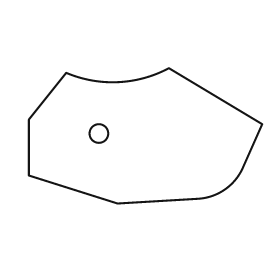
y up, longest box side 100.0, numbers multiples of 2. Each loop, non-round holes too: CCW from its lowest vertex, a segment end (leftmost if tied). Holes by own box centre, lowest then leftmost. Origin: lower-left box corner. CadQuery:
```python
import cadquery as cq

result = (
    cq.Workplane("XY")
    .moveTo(38.0, 0.0)
    .lineTo(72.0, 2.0)
    .threePointArc((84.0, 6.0), (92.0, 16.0))
    .lineTo(100.0, 34.0)
    .lineTo(60.0, 58.0)
    .threePointArc((38.0, 52.0), (16.0, 56.0))
    .lineTo(0.0, 36.0)
    .lineTo(0.0, 12.0)
    .close()
    .moveTo(30.0, 30.0)
    .circle(4.0)
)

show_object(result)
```